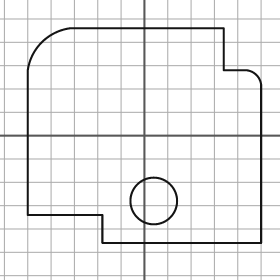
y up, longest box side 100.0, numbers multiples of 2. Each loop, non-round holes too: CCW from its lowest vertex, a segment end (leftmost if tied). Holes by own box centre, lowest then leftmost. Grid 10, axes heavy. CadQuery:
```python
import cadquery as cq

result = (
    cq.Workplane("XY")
    .moveTo(-18.0, -46.0)
    .lineTo(50.0, -46.0)
    .lineTo(50.0, 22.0)
    .threePointArc((48.0, 26.0), (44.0, 28.0))
    .lineTo(34.0, 28.0)
    .lineTo(34.0, 46.0)
    .lineTo(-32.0, 46.0)
    .threePointArc((-44.0, 40.0), (-50.0, 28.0))
    .lineTo(-50.0, -34.0)
    .lineTo(-18.0, -34.0)
    .close()
    .moveTo(4.0, -28.0)
    .circle(10.0)
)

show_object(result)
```